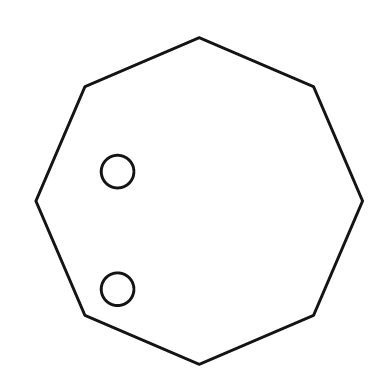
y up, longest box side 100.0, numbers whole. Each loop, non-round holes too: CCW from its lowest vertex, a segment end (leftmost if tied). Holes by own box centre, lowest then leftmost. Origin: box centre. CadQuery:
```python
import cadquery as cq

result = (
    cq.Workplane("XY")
    .moveTo(0.0, -50.0)
    .lineTo(35.0, -35.0)
    .lineTo(50.0, 0.0)
    .lineTo(35.0, 35.0)
    .lineTo(0.0, 50.0)
    .lineTo(-35.0, 35.0)
    .lineTo(-50.0, 0.0)
    .lineTo(-35.0, -35.0)
    .close()
    .moveTo(-25.0, -27.0)
    .circle(5.0)
    .moveTo(-25.0, 9.0)
    .circle(5.0)
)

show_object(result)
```